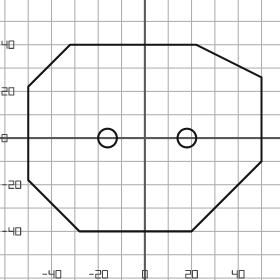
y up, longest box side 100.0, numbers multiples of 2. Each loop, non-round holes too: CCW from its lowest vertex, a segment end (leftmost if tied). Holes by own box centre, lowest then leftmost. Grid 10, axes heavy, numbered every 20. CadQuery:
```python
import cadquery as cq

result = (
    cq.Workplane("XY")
    .moveTo(-28.0, -40.0)
    .lineTo(20.0, -40.0)
    .lineTo(50.0, -10.0)
    .lineTo(50.0, 26.0)
    .lineTo(22.0, 40.0)
    .lineTo(-32.0, 40.0)
    .lineTo(-50.0, 22.0)
    .lineTo(-50.0, -18.0)
    .close()
    .moveTo(-16.0, 0.0)
    .circle(4.0)
    .moveTo(18.0, 0.0)
    .circle(4.0)
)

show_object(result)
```